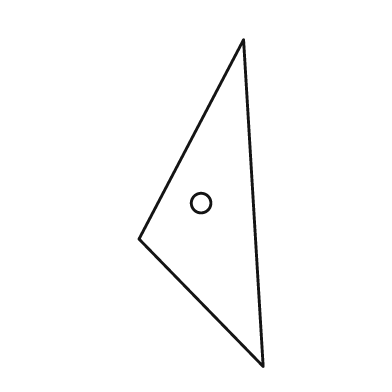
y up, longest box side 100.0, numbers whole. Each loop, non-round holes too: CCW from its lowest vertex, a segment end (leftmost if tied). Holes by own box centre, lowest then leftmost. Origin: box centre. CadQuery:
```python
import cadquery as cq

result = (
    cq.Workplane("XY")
    .moveTo(19.0, -50.0)
    .lineTo(13.0, 50.0)
    .lineTo(-19.0, -11.0)
    .close()
    .moveTo(0.0, 0.0)
    .circle(3.0)
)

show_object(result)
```